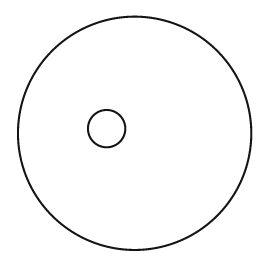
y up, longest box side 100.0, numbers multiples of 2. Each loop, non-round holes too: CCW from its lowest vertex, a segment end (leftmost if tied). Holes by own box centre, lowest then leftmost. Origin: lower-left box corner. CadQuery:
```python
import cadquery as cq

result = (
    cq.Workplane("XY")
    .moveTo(50.0, 50.0)
    .circle(50.0)
    .moveTo(38.0, 52.0)
    .circle(8.0)
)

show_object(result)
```